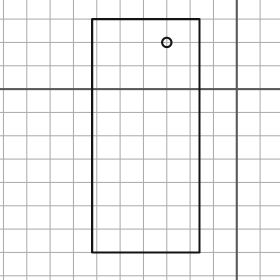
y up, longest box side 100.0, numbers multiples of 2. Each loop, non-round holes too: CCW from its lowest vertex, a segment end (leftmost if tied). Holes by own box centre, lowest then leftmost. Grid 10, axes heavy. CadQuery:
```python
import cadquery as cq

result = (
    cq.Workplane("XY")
    .moveTo(-62.0, -70.0)
    .lineTo(-16.0, -70.0)
    .lineTo(-16.0, 30.0)
    .lineTo(-62.0, 30.0)
    .close()
    .moveTo(-30.0, 20.0)
    .circle(2.0)
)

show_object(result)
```